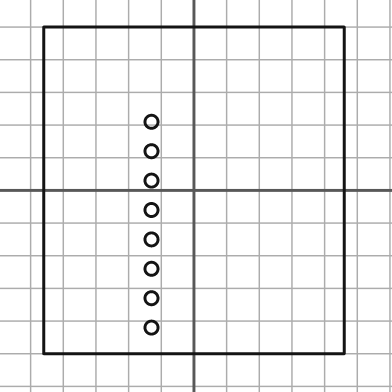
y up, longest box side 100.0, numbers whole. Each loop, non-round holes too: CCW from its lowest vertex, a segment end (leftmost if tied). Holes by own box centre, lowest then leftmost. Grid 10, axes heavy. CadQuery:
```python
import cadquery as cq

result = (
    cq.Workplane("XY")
    .moveTo(-46.0, -50.0)
    .lineTo(46.0, -50.0)
    .lineTo(46.0, 50.0)
    .lineTo(-46.0, 50.0)
    .close()
    .moveTo(-13.0, -42.0)
    .circle(2.0)
    .moveTo(-13.0, -33.0)
    .circle(2.0)
    .moveTo(-13.0, -24.0)
    .circle(2.0)
    .moveTo(-13.0, -15.0)
    .circle(2.0)
    .moveTo(-13.0, -6.0)
    .circle(2.0)
    .moveTo(-13.0, 3.0)
    .circle(2.0)
    .moveTo(-13.0, 12.0)
    .circle(2.0)
    .moveTo(-13.0, 21.0)
    .circle(2.0)
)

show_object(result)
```